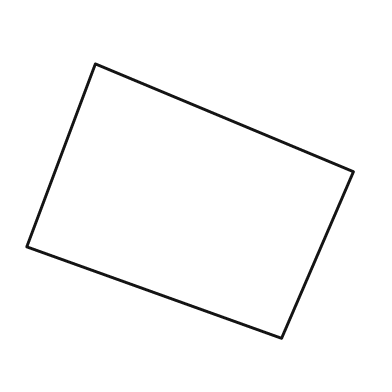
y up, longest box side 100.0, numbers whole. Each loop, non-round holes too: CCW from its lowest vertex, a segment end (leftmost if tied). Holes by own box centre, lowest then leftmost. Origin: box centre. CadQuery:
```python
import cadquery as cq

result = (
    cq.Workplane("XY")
    .moveTo(28.0, -42.0)
    .lineTo(50.0, 9.0)
    .lineTo(-29.0, 42.0)
    .lineTo(-50.0, -14.0)
    .close()
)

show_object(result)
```